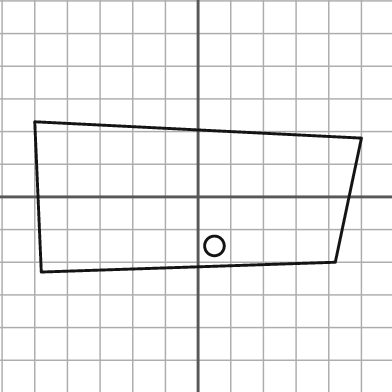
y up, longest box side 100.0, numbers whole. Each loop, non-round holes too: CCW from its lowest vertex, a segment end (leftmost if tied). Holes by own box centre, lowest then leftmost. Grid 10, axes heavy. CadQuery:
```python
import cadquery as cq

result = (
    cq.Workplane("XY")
    .moveTo(-48.0, -23.0)
    .lineTo(42.0, -20.0)
    .lineTo(50.0, 18.0)
    .lineTo(-50.0, 23.0)
    .close()
    .moveTo(5.0, -15.0)
    .circle(3.0)
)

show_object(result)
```